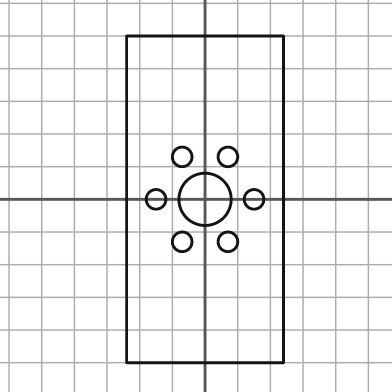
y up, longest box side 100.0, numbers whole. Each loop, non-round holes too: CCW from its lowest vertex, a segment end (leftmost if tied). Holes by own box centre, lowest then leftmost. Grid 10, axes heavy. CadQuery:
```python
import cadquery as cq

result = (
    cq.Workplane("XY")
    .moveTo(-24.0, -50.0)
    .lineTo(24.0, -50.0)
    .lineTo(24.0, 50.0)
    .lineTo(-24.0, 50.0)
    .close()
    .moveTo(-7.0, -13.0)
    .circle(3.0)
    .moveTo(7.0, -13.0)
    .circle(3.0)
    .moveTo(-15.0, 0.0)
    .circle(3.0)
    .moveTo(0.0, 0.0)
    .circle(8.0)
    .moveTo(15.0, 0.0)
    .circle(3.0)
    .moveTo(-7.0, 13.0)
    .circle(3.0)
    .moveTo(7.0, 13.0)
    .circle(3.0)
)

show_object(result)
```